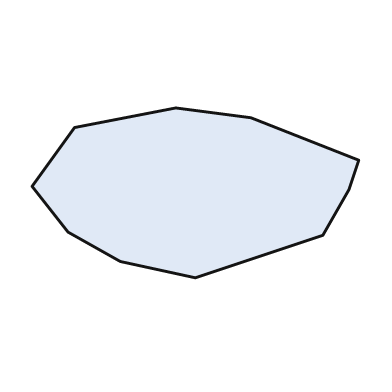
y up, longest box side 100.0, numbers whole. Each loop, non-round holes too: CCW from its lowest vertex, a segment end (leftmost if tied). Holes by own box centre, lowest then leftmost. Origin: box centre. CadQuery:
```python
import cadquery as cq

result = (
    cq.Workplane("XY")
    .moveTo(0.0, -26.0)
    .lineTo(39.0, -13.0)
    .lineTo(47.0, 1.0)
    .lineTo(50.0, 10.0)
    .lineTo(17.0, 23.0)
    .lineTo(-6.0, 26.0)
    .lineTo(-37.0, 20.0)
    .lineTo(-50.0, 2.0)
    .lineTo(-39.0, -12.0)
    .lineTo(-23.0, -21.0)
    .close()
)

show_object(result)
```